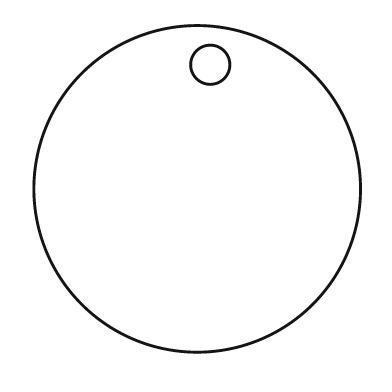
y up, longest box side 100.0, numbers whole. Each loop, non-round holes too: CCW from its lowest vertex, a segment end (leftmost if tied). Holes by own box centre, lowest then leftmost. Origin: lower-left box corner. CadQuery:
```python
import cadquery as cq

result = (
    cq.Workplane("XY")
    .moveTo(50.0, 50.0)
    .circle(50.0)
    .moveTo(54.0, 88.0)
    .circle(6.0)
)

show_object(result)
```